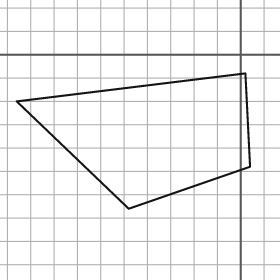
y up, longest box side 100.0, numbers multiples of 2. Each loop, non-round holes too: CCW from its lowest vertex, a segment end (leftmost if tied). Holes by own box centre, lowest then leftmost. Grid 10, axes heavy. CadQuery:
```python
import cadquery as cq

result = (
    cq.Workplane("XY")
    .moveTo(-48.0, -66.0)
    .lineTo(4.0, -48.0)
    .lineTo(2.0, -8.0)
    .lineTo(-96.0, -20.0)
    .close()
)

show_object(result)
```